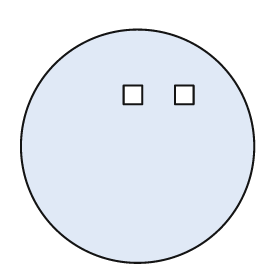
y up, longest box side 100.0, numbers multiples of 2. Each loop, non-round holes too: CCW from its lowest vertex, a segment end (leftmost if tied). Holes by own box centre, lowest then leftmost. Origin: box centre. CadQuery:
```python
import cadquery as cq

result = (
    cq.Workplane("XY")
    .moveTo(0.0, 0.0)
    .circle(50.0)
    .moveTo(-6.0, 18.0)
    .lineTo(2.0, 18.0)
    .lineTo(2.0, 26.0)
    .lineTo(-6.0, 26.0)
    .close()
    .moveTo(16.0, 18.0)
    .lineTo(24.0, 18.0)
    .lineTo(24.0, 26.0)
    .lineTo(16.0, 26.0)
    .close()
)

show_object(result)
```